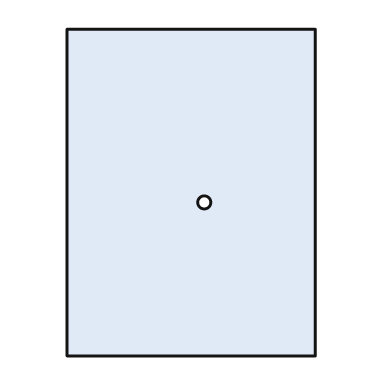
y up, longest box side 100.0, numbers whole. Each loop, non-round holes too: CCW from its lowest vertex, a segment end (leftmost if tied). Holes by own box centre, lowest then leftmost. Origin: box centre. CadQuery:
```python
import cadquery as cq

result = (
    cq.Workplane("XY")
    .moveTo(-38.0, -50.0)
    .lineTo(38.0, -50.0)
    .lineTo(38.0, 50.0)
    .lineTo(-38.0, 50.0)
    .close()
    .moveTo(4.0, -3.0)
    .circle(2.0)
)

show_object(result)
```